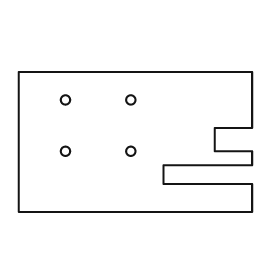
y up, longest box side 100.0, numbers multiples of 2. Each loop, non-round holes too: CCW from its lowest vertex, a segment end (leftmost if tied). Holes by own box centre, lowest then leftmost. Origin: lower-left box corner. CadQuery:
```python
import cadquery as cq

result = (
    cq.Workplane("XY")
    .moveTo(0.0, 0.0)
    .lineTo(100.0, 0.0)
    .lineTo(100.0, 12.0)
    .lineTo(62.0, 12.0)
    .lineTo(62.0, 20.0)
    .lineTo(100.0, 20.0)
    .lineTo(100.0, 26.0)
    .lineTo(84.0, 26.0)
    .lineTo(84.0, 36.0)
    .lineTo(100.0, 36.0)
    .lineTo(100.0, 60.0)
    .lineTo(0.0, 60.0)
    .close()
    .moveTo(20.0, 26.0)
    .circle(2.0)
    .moveTo(48.0, 26.0)
    .circle(2.0)
    .moveTo(20.0, 48.0)
    .circle(2.0)
    .moveTo(48.0, 48.0)
    .circle(2.0)
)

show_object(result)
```